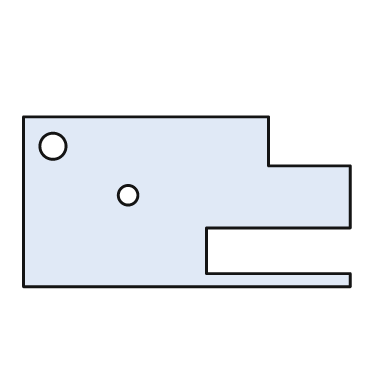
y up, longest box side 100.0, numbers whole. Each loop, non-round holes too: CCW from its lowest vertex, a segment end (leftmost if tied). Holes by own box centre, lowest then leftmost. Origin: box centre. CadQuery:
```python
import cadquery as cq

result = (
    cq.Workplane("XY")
    .moveTo(-50.0, -26.0)
    .lineTo(50.0, -26.0)
    .lineTo(50.0, -22.0)
    .lineTo(6.0, -22.0)
    .lineTo(6.0, -8.0)
    .lineTo(50.0, -8.0)
    .lineTo(50.0, 11.0)
    .lineTo(25.0, 11.0)
    .lineTo(25.0, 26.0)
    .lineTo(-50.0, 26.0)
    .close()
    .moveTo(-18.0, 2.0)
    .circle(3.0)
    .moveTo(-41.0, 17.0)
    .circle(4.0)
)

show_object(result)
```